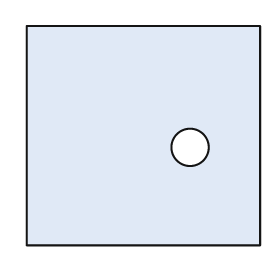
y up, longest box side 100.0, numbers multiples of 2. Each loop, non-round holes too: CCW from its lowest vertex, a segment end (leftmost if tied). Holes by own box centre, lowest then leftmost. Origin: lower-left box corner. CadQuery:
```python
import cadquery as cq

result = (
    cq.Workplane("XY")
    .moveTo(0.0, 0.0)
    .lineTo(100.0, 0.0)
    .lineTo(100.0, 94.0)
    .lineTo(0.0, 94.0)
    .close()
    .moveTo(70.0, 42.0)
    .circle(8.0)
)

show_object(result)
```